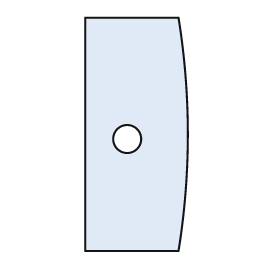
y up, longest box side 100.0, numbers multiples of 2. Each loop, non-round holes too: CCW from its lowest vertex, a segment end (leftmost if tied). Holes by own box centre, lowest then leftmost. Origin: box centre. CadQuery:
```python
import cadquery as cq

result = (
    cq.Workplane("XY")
    .moveTo(-22.0, -50.0)
    .lineTo(18.0, -50.0)
    .threePointArc((22.0, 0.0), (18.0, 50.0))
    .lineTo(-22.0, 50.0)
    .close()
    .moveTo(-4.0, -2.0)
    .circle(6.0)
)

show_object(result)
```